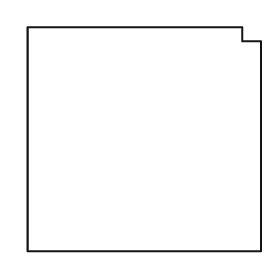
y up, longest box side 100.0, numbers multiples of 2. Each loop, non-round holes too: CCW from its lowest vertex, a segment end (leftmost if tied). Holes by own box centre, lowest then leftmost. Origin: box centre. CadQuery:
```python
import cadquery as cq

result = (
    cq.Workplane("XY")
    .moveTo(-50.0, -48.0)
    .lineTo(50.0, -48.0)
    .lineTo(50.0, 42.0)
    .lineTo(42.0, 42.0)
    .lineTo(42.0, 48.0)
    .lineTo(-50.0, 48.0)
    .close()
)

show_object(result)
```